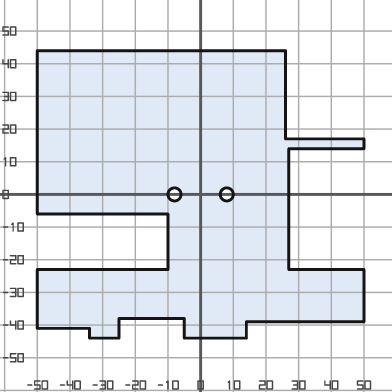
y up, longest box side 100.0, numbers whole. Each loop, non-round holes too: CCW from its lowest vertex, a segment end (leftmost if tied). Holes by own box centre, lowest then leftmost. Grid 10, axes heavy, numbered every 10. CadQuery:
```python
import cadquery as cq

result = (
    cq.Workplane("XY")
    .moveTo(-34.0, -44.0)
    .lineTo(-25.0, -44.0)
    .lineTo(-25.0, -38.0)
    .lineTo(-5.0, -38.0)
    .lineTo(-5.0, -44.0)
    .lineTo(14.0, -44.0)
    .lineTo(14.0, -39.0)
    .lineTo(50.0, -39.0)
    .lineTo(50.0, -23.0)
    .lineTo(27.0, -23.0)
    .lineTo(27.0, 14.0)
    .lineTo(50.0, 14.0)
    .lineTo(50.0, 17.0)
    .lineTo(26.0, 17.0)
    .lineTo(26.0, 44.0)
    .lineTo(-50.0, 44.0)
    .lineTo(-50.0, -6.0)
    .lineTo(-10.0, -6.0)
    .lineTo(-10.0, -23.0)
    .lineTo(-50.0, -23.0)
    .lineTo(-50.0, -41.0)
    .lineTo(-34.0, -41.0)
    .close()
    .moveTo(-8.0, 0.0)
    .circle(2.0)
    .moveTo(8.0, 0.0)
    .circle(2.0)
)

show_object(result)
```